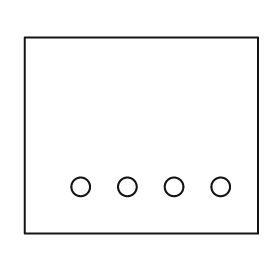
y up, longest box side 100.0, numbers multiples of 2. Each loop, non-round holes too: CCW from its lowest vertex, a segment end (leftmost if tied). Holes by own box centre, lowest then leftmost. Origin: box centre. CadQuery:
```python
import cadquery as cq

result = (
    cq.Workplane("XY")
    .moveTo(-50.0, -42.0)
    .lineTo(50.0, -42.0)
    .lineTo(50.0, 42.0)
    .lineTo(-50.0, 42.0)
    .close()
    .moveTo(-26.0, -22.0)
    .circle(4.0)
    .moveTo(-6.0, -22.0)
    .circle(4.0)
    .moveTo(14.0, -22.0)
    .circle(4.0)
    .moveTo(34.0, -22.0)
    .circle(4.0)
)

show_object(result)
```